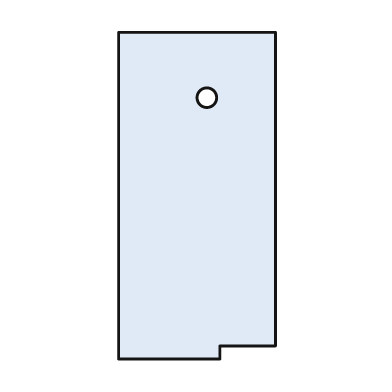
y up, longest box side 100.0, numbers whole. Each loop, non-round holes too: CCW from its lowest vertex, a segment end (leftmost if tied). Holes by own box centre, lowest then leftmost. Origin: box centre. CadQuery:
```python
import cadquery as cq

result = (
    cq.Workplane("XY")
    .moveTo(-24.0, -50.0)
    .lineTo(7.0, -50.0)
    .lineTo(7.0, -46.0)
    .lineTo(24.0, -46.0)
    .lineTo(24.0, 50.0)
    .lineTo(-24.0, 50.0)
    .close()
    .moveTo(3.0, 30.0)
    .circle(3.0)
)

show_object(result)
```